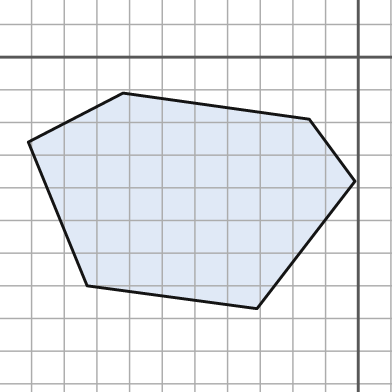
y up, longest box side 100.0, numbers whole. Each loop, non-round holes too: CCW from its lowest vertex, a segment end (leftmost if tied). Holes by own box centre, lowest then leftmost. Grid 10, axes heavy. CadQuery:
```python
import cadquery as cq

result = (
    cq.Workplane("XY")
    .moveTo(-31.0, -77.0)
    .lineTo(-1.0, -38.0)
    .lineTo(-15.0, -19.0)
    .lineTo(-72.0, -11.0)
    .lineTo(-101.0, -26.0)
    .lineTo(-83.0, -70.0)
    .close()
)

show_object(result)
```